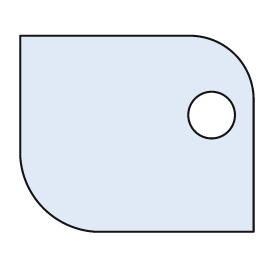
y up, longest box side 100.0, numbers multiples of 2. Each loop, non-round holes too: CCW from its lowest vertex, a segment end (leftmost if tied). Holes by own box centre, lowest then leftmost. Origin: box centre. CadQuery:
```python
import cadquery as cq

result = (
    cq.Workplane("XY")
    .moveTo(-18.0, -42.0)
    .lineTo(50.0, -42.0)
    .lineTo(50.0, 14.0)
    .threePointArc((42.0, 34.0), (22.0, 42.0))
    .lineTo(-50.0, 42.0)
    .lineTo(-50.0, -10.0)
    .threePointArc((-40.0, -32.0), (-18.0, -42.0))
    .close()
    .moveTo(32.0, 8.0)
    .circle(10.0)
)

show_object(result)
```